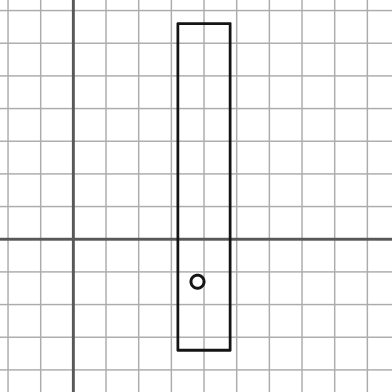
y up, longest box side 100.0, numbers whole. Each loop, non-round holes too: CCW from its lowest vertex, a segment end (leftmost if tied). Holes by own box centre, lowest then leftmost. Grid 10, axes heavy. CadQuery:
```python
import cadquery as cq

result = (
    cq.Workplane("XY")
    .moveTo(32.0, -34.0)
    .lineTo(48.0, -34.0)
    .lineTo(48.0, 66.0)
    .lineTo(32.0, 66.0)
    .close()
    .moveTo(38.0, -13.0)
    .circle(2.0)
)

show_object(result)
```